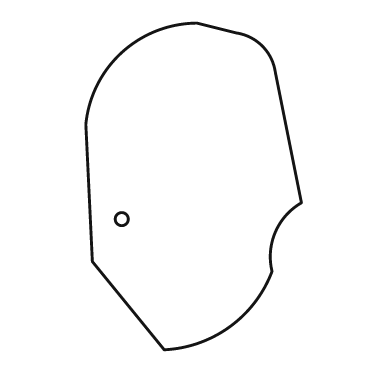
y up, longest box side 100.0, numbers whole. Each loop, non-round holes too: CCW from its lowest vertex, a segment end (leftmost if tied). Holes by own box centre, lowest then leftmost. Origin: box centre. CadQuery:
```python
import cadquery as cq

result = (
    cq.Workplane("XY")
    .moveTo(-9.0, -50.0)
    .threePointArc((11.0, -43.0), (24.0, -26.0))
    .threePointArc((25.0, -14.0), (33.0, -5.0))
    .lineTo(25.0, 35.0)
    .threePointArc((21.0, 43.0), (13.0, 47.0))
    .lineTo(1.0, 50.0)
    .threePointArc((-22.0, 41.0), (-33.0, 19.0))
    .lineTo(-31.0, -23.0)
    .close()
    .moveTo(-22.0, -10.0)
    .circle(2.0)
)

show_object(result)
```